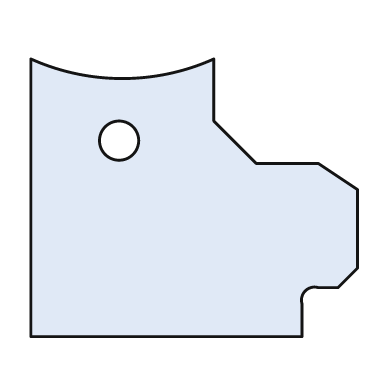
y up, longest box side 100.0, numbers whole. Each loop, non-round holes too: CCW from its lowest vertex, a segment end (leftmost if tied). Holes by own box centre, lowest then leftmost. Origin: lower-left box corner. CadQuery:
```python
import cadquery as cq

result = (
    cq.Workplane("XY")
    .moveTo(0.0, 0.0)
    .lineTo(83.0, 0.0)
    .lineTo(83.0, 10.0)
    .threePointArc((84.0, 14.0), (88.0, 15.0))
    .lineTo(94.0, 15.0)
    .lineTo(100.0, 21.0)
    .lineTo(100.0, 45.0)
    .lineTo(88.0, 53.0)
    .lineTo(69.0, 53.0)
    .lineTo(56.0, 66.0)
    .lineTo(56.0, 85.0)
    .threePointArc((28.0, 79.0), (0.0, 85.0))
    .close()
    .moveTo(27.0, 60.0)
    .circle(6.0)
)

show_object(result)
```